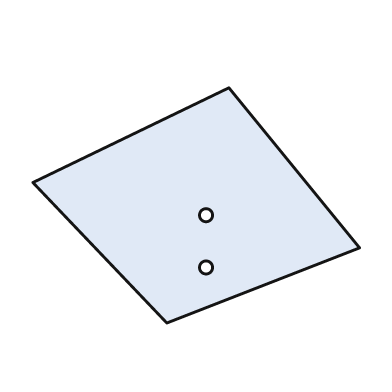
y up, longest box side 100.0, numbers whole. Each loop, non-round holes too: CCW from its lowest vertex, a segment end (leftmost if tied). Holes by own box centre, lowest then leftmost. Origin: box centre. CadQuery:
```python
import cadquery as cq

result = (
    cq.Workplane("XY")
    .moveTo(-9.0, -36.0)
    .lineTo(50.0, -13.0)
    .lineTo(10.0, 36.0)
    .lineTo(-50.0, 7.0)
    .close()
    .moveTo(3.0, -19.0)
    .circle(2.0)
    .moveTo(3.0, -3.0)
    .circle(2.0)
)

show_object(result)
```